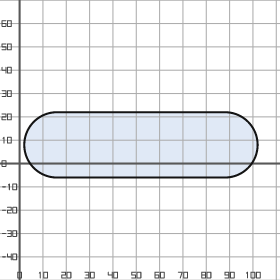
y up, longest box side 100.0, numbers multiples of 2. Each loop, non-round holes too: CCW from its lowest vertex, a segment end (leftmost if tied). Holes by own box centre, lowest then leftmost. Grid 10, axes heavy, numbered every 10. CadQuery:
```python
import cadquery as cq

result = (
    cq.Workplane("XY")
    .moveTo(16.0, -6.0)
    .lineTo(88.0, -6.0)
    .threePointArc((102.0, 8.0), (88.0, 22.0))
    .lineTo(16.0, 22.0)
    .threePointArc((2.0, 8.0), (16.0, -6.0))
    .close()
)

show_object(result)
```